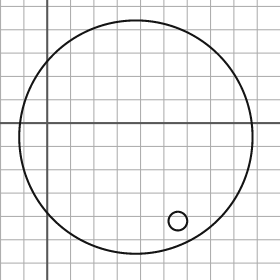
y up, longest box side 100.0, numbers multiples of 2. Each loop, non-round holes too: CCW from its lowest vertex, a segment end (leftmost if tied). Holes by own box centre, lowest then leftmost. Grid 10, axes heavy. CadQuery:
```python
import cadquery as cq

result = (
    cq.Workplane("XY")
    .moveTo(38.0, -6.0)
    .circle(50.0)
    .moveTo(56.0, -42.0)
    .circle(4.0)
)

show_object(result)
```